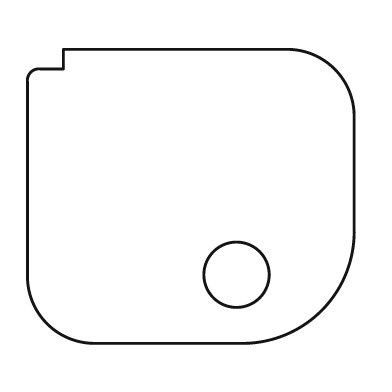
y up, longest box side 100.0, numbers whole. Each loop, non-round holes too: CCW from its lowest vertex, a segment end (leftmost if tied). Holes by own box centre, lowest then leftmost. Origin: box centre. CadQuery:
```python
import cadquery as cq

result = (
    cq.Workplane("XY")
    .moveTo(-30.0, -45.0)
    .lineTo(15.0, -45.0)
    .threePointArc((40.0, -35.0), (50.0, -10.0))
    .lineTo(50.0, 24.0)
    .threePointArc((44.0, 39.0), (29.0, 45.0))
    .lineTo(-39.0, 45.0)
    .lineTo(-39.0, 39.0)
    .lineTo(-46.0, 39.0)
    .threePointArc((-49.0, 38.0), (-50.0, 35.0))
    .lineTo(-50.0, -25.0)
    .threePointArc((-44.0, -39.0), (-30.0, -45.0))
    .close()
    .moveTo(14.0, -24.0)
    .circle(10.0)
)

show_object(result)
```